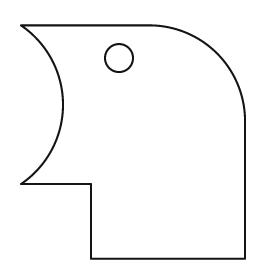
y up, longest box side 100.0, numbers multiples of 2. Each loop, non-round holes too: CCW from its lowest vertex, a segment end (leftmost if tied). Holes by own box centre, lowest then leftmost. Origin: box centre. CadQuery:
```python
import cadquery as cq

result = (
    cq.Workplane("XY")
    .moveTo(-18.0, -50.0)
    .lineTo(48.0, -50.0)
    .lineTo(48.0, 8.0)
    .threePointArc((36.0, 38.0), (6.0, 50.0))
    .lineTo(-48.0, 50.0)
    .threePointArc((-30.0, 16.0), (-48.0, -18.0))
    .lineTo(-18.0, -18.0)
    .close()
    .moveTo(-6.0, 36.0)
    .circle(6.0)
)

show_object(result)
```